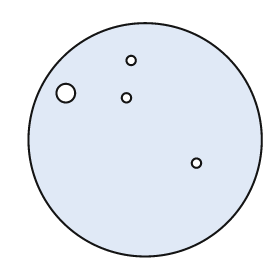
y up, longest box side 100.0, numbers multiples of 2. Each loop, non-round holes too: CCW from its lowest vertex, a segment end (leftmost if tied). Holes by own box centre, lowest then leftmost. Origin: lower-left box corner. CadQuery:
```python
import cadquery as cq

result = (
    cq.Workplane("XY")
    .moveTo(50.0, 50.0)
    .circle(50.0)
    .moveTo(72.0, 40.0)
    .circle(2.0)
    .moveTo(42.0, 68.0)
    .circle(2.0)
    .moveTo(16.0, 70.0)
    .circle(4.0)
    .moveTo(44.0, 84.0)
    .circle(2.0)
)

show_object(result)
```